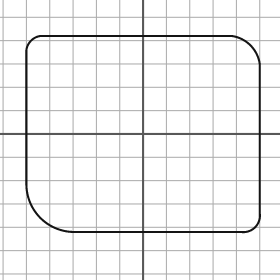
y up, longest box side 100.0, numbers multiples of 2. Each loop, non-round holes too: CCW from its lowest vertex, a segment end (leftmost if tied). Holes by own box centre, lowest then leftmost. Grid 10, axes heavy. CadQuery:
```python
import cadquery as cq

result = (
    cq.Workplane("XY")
    .moveTo(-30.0, -42.0)
    .lineTo(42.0, -42.0)
    .threePointArc((48.0, -40.0), (50.0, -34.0))
    .lineTo(50.0, 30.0)
    .threePointArc((46.0, 38.0), (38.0, 42.0))
    .lineTo(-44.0, 42.0)
    .threePointArc((-48.0, 40.0), (-50.0, 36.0))
    .lineTo(-50.0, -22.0)
    .threePointArc((-44.0, -36.0), (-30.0, -42.0))
    .close()
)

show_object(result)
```